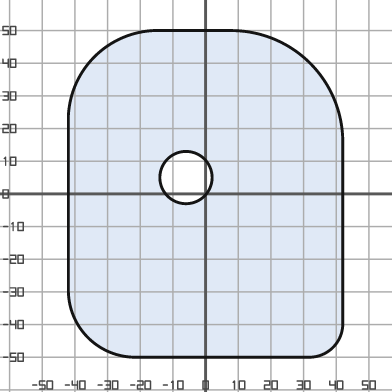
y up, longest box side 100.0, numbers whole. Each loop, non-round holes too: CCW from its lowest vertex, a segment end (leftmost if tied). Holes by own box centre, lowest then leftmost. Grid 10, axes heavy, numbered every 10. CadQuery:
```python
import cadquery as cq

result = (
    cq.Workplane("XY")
    .moveTo(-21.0, -50.0)
    .lineTo(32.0, -50.0)
    .threePointArc((39.0, -47.0), (42.0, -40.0))
    .lineTo(42.0, 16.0)
    .threePointArc((32.0, 40.0), (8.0, 50.0))
    .lineTo(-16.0, 50.0)
    .threePointArc((-34.0, 42.0), (-42.0, 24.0))
    .lineTo(-42.0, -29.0)
    .threePointArc((-36.0, -44.0), (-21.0, -50.0))
    .close()
    .moveTo(-6.0, 5.0)
    .circle(8.0)
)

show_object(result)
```